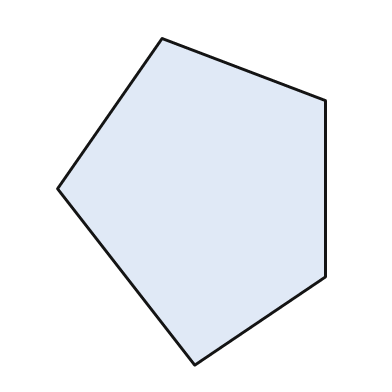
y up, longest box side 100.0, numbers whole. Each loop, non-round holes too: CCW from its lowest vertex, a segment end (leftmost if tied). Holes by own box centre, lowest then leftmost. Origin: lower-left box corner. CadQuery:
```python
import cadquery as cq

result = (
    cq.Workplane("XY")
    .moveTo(42.0, 0.0)
    .lineTo(82.0, 27.0)
    .lineTo(82.0, 81.0)
    .lineTo(32.0, 100.0)
    .lineTo(0.0, 54.0)
    .close()
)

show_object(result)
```